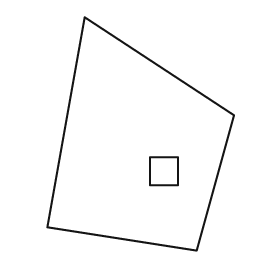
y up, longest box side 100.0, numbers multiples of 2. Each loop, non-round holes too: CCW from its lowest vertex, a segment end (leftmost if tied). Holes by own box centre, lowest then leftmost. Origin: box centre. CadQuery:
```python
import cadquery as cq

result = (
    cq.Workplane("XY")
    .moveTo(24.0, -50.0)
    .lineTo(40.0, 8.0)
    .lineTo(-24.0, 50.0)
    .lineTo(-40.0, -40.0)
    .close()
    .moveTo(4.0, -22.0)
    .lineTo(16.0, -22.0)
    .lineTo(16.0, -10.0)
    .lineTo(4.0, -10.0)
    .close()
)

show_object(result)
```